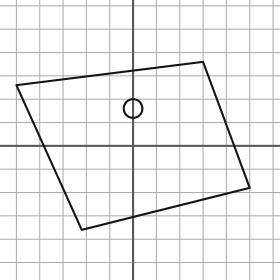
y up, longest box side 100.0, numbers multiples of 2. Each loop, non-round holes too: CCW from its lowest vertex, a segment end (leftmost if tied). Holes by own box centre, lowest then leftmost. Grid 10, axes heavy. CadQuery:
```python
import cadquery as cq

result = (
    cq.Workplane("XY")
    .moveTo(-22.0, -36.0)
    .lineTo(50.0, -18.0)
    .lineTo(30.0, 36.0)
    .lineTo(-50.0, 26.0)
    .close()
    .moveTo(0.0, 16.0)
    .circle(4.0)
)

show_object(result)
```